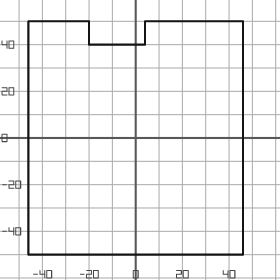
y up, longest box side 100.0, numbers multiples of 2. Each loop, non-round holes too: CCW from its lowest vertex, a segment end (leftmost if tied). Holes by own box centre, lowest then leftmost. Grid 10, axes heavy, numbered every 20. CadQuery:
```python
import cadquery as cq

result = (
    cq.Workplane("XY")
    .moveTo(-46.0, -50.0)
    .lineTo(46.0, -50.0)
    .lineTo(46.0, 50.0)
    .lineTo(4.0, 50.0)
    .lineTo(4.0, 40.0)
    .lineTo(-20.0, 40.0)
    .lineTo(-20.0, 50.0)
    .lineTo(-46.0, 50.0)
    .close()
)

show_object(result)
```